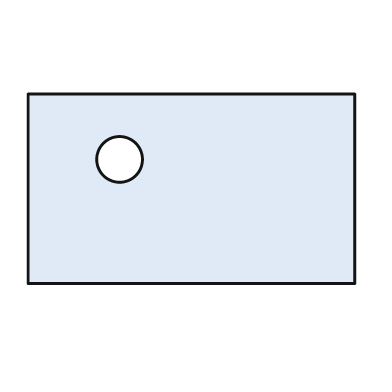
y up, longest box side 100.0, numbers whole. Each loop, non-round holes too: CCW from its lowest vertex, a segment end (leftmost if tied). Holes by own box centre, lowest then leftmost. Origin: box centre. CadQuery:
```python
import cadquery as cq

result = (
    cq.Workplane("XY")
    .moveTo(-50.0, -29.0)
    .lineTo(50.0, -29.0)
    .lineTo(50.0, 29.0)
    .lineTo(-50.0, 29.0)
    .close()
    .moveTo(-22.0, 9.0)
    .circle(7.0)
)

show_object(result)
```